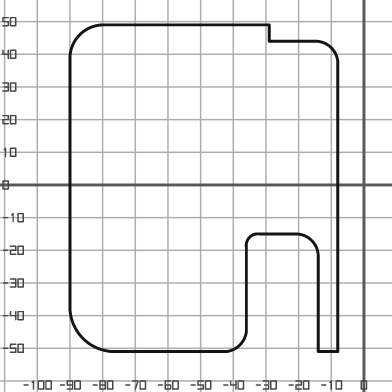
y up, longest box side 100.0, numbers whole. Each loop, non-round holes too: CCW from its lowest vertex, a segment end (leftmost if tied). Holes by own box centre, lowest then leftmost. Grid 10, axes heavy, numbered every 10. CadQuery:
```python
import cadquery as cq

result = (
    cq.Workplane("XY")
    .moveTo(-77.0, -51.0)
    .lineTo(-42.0, -51.0)
    .threePointArc((-38.0, -49.0), (-36.0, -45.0))
    .lineTo(-36.0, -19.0)
    .threePointArc((-35.0, -16.0), (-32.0, -15.0))
    .lineTo(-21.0, -15.0)
    .threePointArc((-16.0, -17.0), (-14.0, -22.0))
    .lineTo(-14.0, -51.0)
    .lineTo(-8.0, -51.0)
    .lineTo(-8.0, 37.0)
    .threePointArc((-10.0, 42.0), (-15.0, 44.0))
    .lineTo(-29.0, 44.0)
    .lineTo(-29.0, 49.0)
    .lineTo(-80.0, 49.0)
    .threePointArc((-87.0, 46.0), (-90.0, 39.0))
    .lineTo(-90.0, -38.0)
    .threePointArc((-86.0, -47.0), (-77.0, -51.0))
    .close()
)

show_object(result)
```